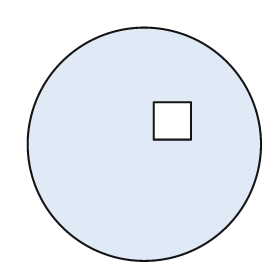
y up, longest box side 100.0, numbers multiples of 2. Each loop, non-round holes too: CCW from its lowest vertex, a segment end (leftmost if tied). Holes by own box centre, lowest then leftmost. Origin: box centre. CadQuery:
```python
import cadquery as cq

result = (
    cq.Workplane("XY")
    .moveTo(0.0, 0.0)
    .circle(50.0)
    .moveTo(4.0, 2.0)
    .lineTo(20.0, 2.0)
    .lineTo(20.0, 18.0)
    .lineTo(4.0, 18.0)
    .close()
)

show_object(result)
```